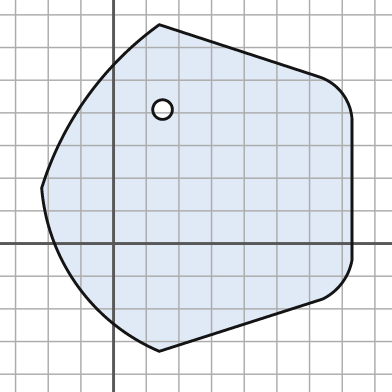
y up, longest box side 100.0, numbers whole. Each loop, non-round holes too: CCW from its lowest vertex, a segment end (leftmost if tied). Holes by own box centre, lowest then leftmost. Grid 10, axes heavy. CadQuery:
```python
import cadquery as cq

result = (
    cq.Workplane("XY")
    .moveTo(14.0, -33.0)
    .lineTo(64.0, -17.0)
    .threePointArc((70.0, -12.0), (73.0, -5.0))
    .lineTo(73.0, 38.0)
    .threePointArc((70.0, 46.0), (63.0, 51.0))
    .lineTo(14.0, 67.0)
    .threePointArc((-8.0, 45.0), (-22.0, 17.0))
    .threePointArc((-11.0, -13.0), (14.0, -33.0))
    .close()
    .moveTo(15.0, 41.0)
    .circle(3.0)
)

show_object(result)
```